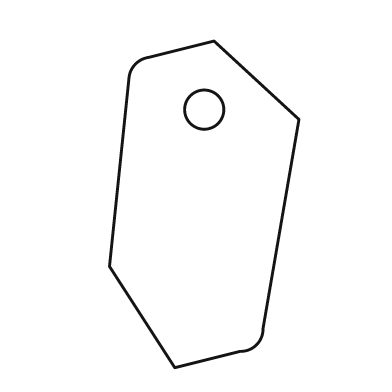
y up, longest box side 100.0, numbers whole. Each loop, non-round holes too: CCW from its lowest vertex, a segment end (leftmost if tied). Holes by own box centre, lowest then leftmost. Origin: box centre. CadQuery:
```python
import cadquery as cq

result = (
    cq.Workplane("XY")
    .moveTo(-9.0, -50.0)
    .lineTo(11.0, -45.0)
    .threePointArc((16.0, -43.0), (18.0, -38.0))
    .lineTo(29.0, 26.0)
    .lineTo(3.0, 50.0)
    .lineTo(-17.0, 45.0)
    .threePointArc((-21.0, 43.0), (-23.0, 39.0))
    .lineTo(-29.0, -19.0)
    .close()
    .moveTo(0.0, 29.0)
    .circle(6.0)
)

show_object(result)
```